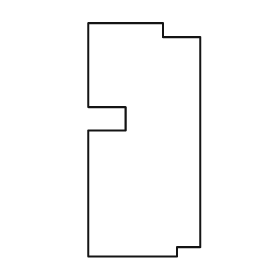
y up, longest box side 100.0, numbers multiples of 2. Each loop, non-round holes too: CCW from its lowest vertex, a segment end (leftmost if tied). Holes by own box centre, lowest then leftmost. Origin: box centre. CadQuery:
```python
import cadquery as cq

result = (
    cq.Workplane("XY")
    .moveTo(-24.0, -50.0)
    .lineTo(14.0, -50.0)
    .lineTo(14.0, -46.0)
    .lineTo(24.0, -46.0)
    .lineTo(24.0, 44.0)
    .lineTo(8.0, 44.0)
    .lineTo(8.0, 50.0)
    .lineTo(-24.0, 50.0)
    .lineTo(-24.0, 14.0)
    .lineTo(-8.0, 14.0)
    .lineTo(-8.0, 4.0)
    .lineTo(-24.0, 4.0)
    .close()
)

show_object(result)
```